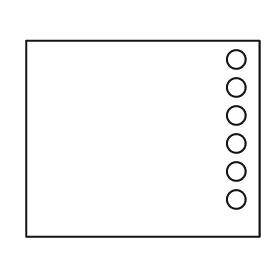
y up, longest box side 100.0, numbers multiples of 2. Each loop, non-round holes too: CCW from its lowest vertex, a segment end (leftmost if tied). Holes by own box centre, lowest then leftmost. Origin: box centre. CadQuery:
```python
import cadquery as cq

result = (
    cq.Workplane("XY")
    .moveTo(-50.0, -42.0)
    .lineTo(50.0, -42.0)
    .lineTo(50.0, 42.0)
    .lineTo(-50.0, 42.0)
    .close()
    .moveTo(40.0, -26.0)
    .circle(4.0)
    .moveTo(40.0, -14.0)
    .circle(4.0)
    .moveTo(40.0, -2.0)
    .circle(4.0)
    .moveTo(40.0, 10.0)
    .circle(4.0)
    .moveTo(40.0, 22.0)
    .circle(4.0)
    .moveTo(40.0, 34.0)
    .circle(4.0)
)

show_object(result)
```